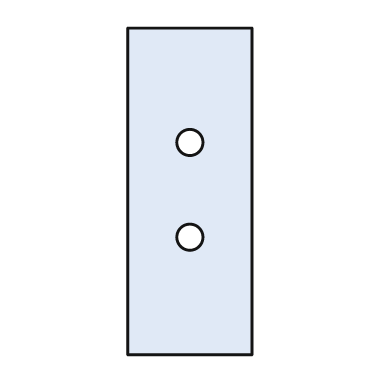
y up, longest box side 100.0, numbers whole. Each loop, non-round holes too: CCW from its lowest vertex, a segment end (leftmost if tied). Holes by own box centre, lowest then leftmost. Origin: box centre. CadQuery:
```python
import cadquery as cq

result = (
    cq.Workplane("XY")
    .moveTo(-19.0, -50.0)
    .lineTo(19.0, -50.0)
    .lineTo(19.0, 50.0)
    .lineTo(-19.0, 50.0)
    .close()
    .moveTo(0.0, -14.0)
    .circle(4.0)
    .moveTo(0.0, 15.0)
    .circle(4.0)
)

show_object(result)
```